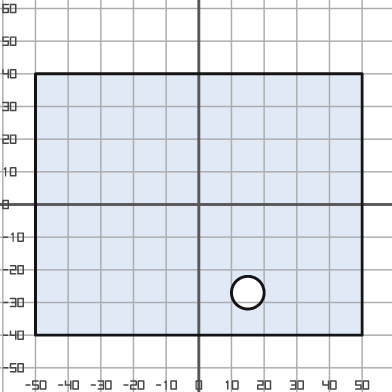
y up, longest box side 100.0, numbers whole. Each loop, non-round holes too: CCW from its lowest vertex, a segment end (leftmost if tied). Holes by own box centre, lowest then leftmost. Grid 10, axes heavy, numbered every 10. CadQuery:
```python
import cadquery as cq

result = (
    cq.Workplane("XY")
    .moveTo(-50.0, -40.0)
    .lineTo(50.0, -40.0)
    .lineTo(50.0, 40.0)
    .lineTo(-50.0, 40.0)
    .close()
    .moveTo(15.0, -27.0)
    .circle(5.0)
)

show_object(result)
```